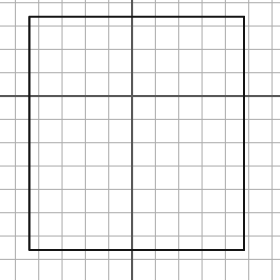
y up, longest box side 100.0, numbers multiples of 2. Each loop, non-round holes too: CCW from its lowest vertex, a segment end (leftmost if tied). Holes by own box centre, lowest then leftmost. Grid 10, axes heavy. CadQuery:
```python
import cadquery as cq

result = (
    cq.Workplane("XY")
    .moveTo(-44.0, -66.0)
    .lineTo(48.0, -66.0)
    .lineTo(48.0, 34.0)
    .lineTo(-44.0, 34.0)
    .close()
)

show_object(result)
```